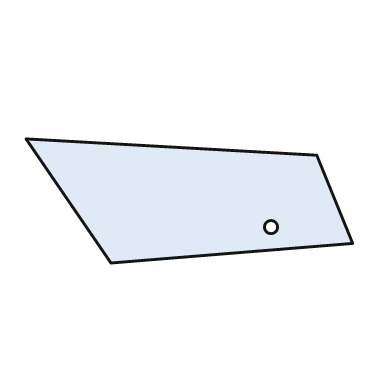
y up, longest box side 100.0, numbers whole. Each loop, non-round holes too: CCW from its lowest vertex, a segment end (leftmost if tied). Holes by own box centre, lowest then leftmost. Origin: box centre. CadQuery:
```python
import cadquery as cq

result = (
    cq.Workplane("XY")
    .moveTo(-24.0, -19.0)
    .lineTo(50.0, -13.0)
    .lineTo(39.0, 14.0)
    .lineTo(-50.0, 19.0)
    .close()
    .moveTo(25.0, -8.0)
    .circle(2.0)
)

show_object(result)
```